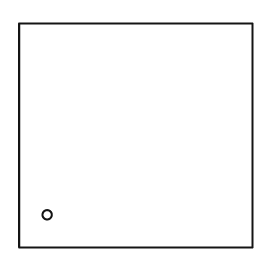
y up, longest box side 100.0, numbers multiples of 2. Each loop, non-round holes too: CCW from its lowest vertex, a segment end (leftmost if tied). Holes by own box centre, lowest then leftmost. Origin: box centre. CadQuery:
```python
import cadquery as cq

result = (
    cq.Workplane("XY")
    .moveTo(-50.0, -48.0)
    .lineTo(50.0, -48.0)
    .lineTo(50.0, 48.0)
    .lineTo(-50.0, 48.0)
    .close()
    .moveTo(-38.0, -34.0)
    .circle(2.0)
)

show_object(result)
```